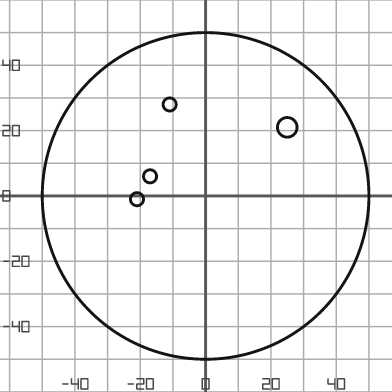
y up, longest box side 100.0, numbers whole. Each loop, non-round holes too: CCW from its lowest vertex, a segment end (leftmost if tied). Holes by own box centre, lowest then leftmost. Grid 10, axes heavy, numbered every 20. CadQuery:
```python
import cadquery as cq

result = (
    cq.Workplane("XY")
    .moveTo(0.0, 0.0)
    .circle(50.0)
    .moveTo(-21.0, -1.0)
    .circle(2.0)
    .moveTo(-17.0, 6.0)
    .circle(2.0)
    .moveTo(25.0, 21.0)
    .circle(3.0)
    .moveTo(-11.0, 28.0)
    .circle(2.0)
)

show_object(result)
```